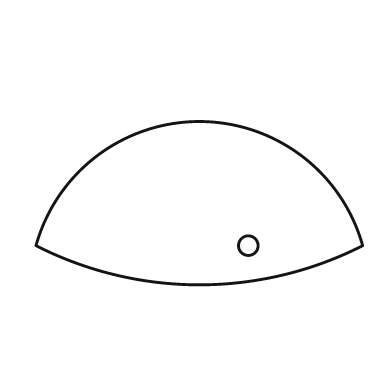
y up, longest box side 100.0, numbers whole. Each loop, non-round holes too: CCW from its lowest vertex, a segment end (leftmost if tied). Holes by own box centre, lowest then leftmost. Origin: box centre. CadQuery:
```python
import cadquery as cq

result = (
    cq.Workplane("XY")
    .moveTo(-50.0, -13.0)
    .threePointArc((0.0, -25.0), (50.0, -13.0))
    .threePointArc((0.0, 25.0), (-50.0, -13.0))
    .close()
    .moveTo(15.0, -13.0)
    .circle(3.0)
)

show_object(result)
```